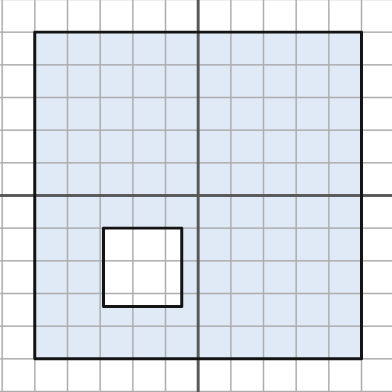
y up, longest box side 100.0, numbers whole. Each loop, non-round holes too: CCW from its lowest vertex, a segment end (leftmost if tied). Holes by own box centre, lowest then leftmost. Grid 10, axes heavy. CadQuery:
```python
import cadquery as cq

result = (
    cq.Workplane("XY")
    .moveTo(-50.0, -50.0)
    .lineTo(50.0, -50.0)
    .lineTo(50.0, 50.0)
    .lineTo(-50.0, 50.0)
    .close()
    .moveTo(-29.0, -34.0)
    .lineTo(-5.0, -34.0)
    .lineTo(-5.0, -10.0)
    .lineTo(-29.0, -10.0)
    .close()
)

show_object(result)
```